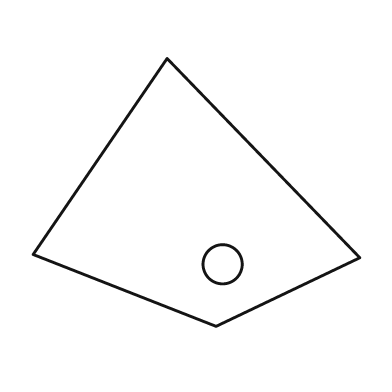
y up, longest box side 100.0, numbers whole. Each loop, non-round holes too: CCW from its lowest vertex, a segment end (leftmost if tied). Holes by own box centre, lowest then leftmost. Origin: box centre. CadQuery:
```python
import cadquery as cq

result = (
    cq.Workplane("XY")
    .moveTo(6.0, -41.0)
    .lineTo(50.0, -20.0)
    .lineTo(-9.0, 41.0)
    .lineTo(-50.0, -19.0)
    .close()
    .moveTo(8.0, -22.0)
    .circle(6.0)
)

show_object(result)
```